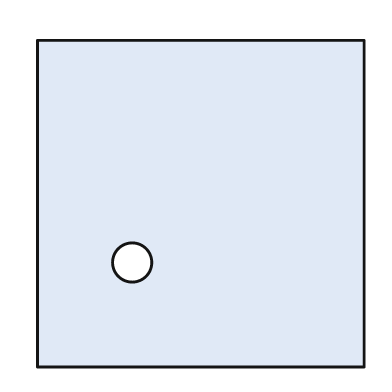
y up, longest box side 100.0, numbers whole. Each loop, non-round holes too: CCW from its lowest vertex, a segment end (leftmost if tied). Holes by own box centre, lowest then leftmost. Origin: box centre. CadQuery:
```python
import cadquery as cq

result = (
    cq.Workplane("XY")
    .moveTo(-50.0, -50.0)
    .lineTo(50.0, -50.0)
    .lineTo(50.0, 50.0)
    .lineTo(-50.0, 50.0)
    .close()
    .moveTo(-21.0, -18.0)
    .circle(6.0)
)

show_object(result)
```